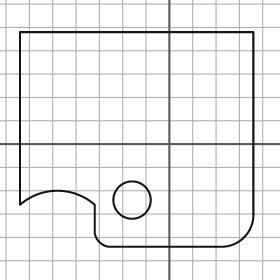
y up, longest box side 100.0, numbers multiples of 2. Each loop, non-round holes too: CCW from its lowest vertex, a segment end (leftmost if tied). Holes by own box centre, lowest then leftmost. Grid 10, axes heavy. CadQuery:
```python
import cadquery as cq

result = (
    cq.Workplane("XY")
    .moveTo(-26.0, -44.0)
    .lineTo(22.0, -44.0)
    .threePointArc((32.0, -40.0), (36.0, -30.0))
    .lineTo(36.0, 48.0)
    .lineTo(-64.0, 48.0)
    .lineTo(-64.0, -26.0)
    .threePointArc((-48.0, -20.0), (-32.0, -26.0))
    .lineTo(-32.0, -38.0)
    .threePointArc((-30.0, -42.0), (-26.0, -44.0))
    .close()
    .moveTo(-16.0, -24.0)
    .circle(8.0)
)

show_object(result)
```